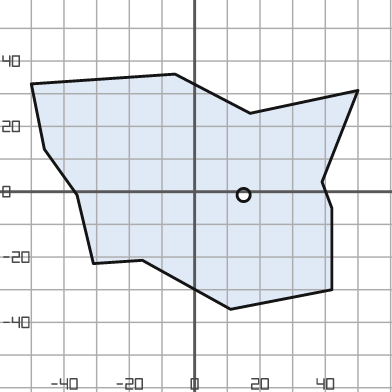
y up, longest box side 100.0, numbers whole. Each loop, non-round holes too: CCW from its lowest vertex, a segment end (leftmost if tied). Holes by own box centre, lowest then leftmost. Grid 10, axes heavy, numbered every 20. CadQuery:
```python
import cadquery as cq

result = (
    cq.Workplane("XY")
    .moveTo(11.0, -36.0)
    .lineTo(42.0, -30.0)
    .lineTo(42.0, -5.0)
    .lineTo(39.0, 3.0)
    .lineTo(50.0, 31.0)
    .lineTo(17.0, 24.0)
    .lineTo(-6.0, 36.0)
    .lineTo(-50.0, 33.0)
    .lineTo(-46.0, 13.0)
    .lineTo(-36.0, -1.0)
    .lineTo(-31.0, -22.0)
    .lineTo(-16.0, -21.0)
    .close()
    .moveTo(15.0, -1.0)
    .circle(2.0)
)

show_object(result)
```